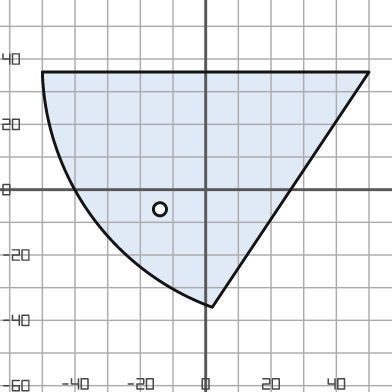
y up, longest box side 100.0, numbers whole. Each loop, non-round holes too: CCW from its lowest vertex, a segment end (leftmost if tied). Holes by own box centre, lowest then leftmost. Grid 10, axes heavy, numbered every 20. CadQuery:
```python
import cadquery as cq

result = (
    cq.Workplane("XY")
    .moveTo(2.0, -36.0)
    .lineTo(50.0, 36.0)
    .lineTo(-50.0, 36.0)
    .threePointArc((-35.0, -8.0), (2.0, -36.0))
    .close()
    .moveTo(-14.0, -6.0)
    .circle(2.0)
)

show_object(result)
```